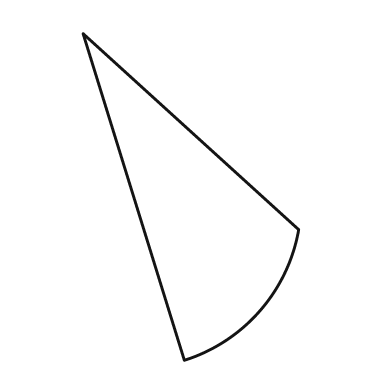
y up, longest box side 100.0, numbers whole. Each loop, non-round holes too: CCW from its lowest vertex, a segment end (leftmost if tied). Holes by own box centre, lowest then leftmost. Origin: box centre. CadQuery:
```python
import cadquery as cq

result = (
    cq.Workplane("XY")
    .moveTo(-2.0, -50.0)
    .threePointArc((21.0, -35.0), (33.0, -10.0))
    .lineTo(-33.0, 50.0)
    .close()
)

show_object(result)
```